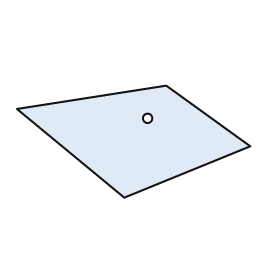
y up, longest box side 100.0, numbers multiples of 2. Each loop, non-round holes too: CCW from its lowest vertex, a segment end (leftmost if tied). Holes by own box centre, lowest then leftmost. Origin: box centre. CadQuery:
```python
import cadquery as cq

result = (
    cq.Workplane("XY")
    .moveTo(-4.0, -24.0)
    .lineTo(50.0, -2.0)
    .lineTo(14.0, 24.0)
    .lineTo(-50.0, 14.0)
    .close()
    .moveTo(6.0, 10.0)
    .circle(2.0)
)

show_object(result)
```